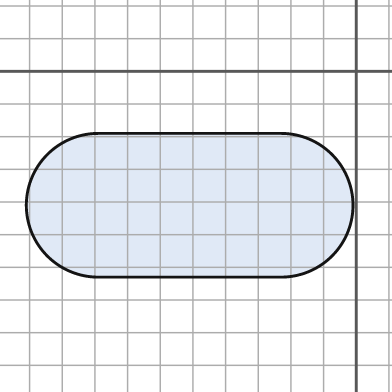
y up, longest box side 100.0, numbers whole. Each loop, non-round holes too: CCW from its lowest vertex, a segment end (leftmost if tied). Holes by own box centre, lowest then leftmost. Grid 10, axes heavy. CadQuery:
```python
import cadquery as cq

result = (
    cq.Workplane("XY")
    .moveTo(-79.0, -63.0)
    .lineTo(-23.0, -63.0)
    .threePointArc((-1.0, -41.0), (-23.0, -19.0))
    .lineTo(-79.0, -19.0)
    .threePointArc((-101.0, -41.0), (-79.0, -63.0))
    .close()
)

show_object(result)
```